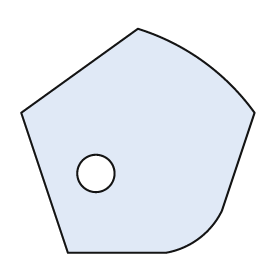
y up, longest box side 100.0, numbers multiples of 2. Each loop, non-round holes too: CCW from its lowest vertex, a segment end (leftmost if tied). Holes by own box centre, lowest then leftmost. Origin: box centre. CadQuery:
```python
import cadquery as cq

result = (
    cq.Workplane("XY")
    .moveTo(-30.0, -48.0)
    .lineTo(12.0, -48.0)
    .threePointArc((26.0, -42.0), (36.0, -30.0))
    .lineTo(50.0, 12.0)
    .threePointArc((28.0, 34.0), (0.0, 48.0))
    .lineTo(-50.0, 12.0)
    .close()
    .moveTo(-18.0, -14.0)
    .circle(8.0)
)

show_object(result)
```